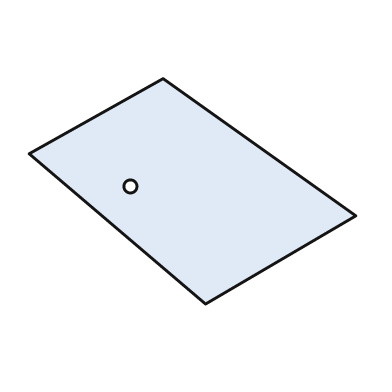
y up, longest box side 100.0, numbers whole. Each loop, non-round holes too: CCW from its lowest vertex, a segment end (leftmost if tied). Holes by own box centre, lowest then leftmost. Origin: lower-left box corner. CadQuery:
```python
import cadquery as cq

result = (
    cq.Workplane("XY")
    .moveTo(54.0, 0.0)
    .lineTo(100.0, 27.0)
    .lineTo(41.0, 69.0)
    .lineTo(0.0, 46.0)
    .close()
    .moveTo(31.0, 36.0)
    .circle(2.0)
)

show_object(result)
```